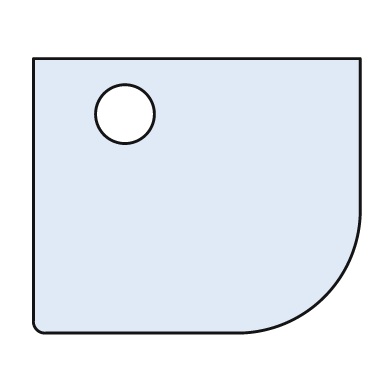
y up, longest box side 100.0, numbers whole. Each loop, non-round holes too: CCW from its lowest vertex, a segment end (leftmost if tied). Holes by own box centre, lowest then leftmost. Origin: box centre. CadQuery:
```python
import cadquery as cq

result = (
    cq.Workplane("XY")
    .moveTo(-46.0, -42.0)
    .lineTo(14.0, -42.0)
    .threePointArc((39.0, -31.0), (50.0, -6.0))
    .lineTo(50.0, 42.0)
    .lineTo(-50.0, 42.0)
    .lineTo(-50.0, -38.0)
    .threePointArc((-49.0, -41.0), (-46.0, -42.0))
    .close()
    .moveTo(-22.0, 25.0)
    .circle(9.0)
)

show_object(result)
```